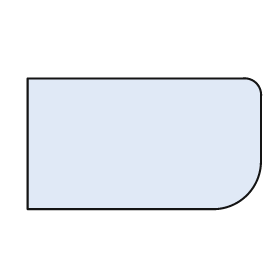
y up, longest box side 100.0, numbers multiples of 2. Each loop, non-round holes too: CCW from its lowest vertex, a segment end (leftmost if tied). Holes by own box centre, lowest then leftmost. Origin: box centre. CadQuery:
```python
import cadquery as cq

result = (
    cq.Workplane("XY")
    .moveTo(-50.0, -28.0)
    .lineTo(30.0, -28.0)
    .threePointArc((44.0, -22.0), (50.0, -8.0))
    .lineTo(50.0, 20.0)
    .threePointArc((48.0, 26.0), (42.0, 28.0))
    .lineTo(-50.0, 28.0)
    .close()
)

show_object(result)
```